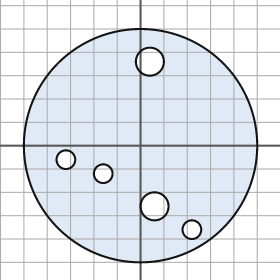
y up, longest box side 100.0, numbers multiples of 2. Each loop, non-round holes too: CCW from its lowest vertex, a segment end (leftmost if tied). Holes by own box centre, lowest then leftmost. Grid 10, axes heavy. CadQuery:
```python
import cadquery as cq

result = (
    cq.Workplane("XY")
    .moveTo(0.0, 0.0)
    .circle(50.0)
    .moveTo(22.0, -36.0)
    .circle(4.0)
    .moveTo(6.0, -26.0)
    .circle(6.0)
    .moveTo(-16.0, -12.0)
    .circle(4.0)
    .moveTo(-32.0, -6.0)
    .circle(4.0)
    .moveTo(4.0, 36.0)
    .circle(6.0)
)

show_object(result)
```